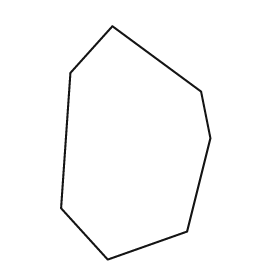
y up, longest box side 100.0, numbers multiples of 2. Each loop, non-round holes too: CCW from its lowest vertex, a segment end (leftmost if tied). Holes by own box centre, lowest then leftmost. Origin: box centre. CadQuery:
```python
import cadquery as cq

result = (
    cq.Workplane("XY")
    .moveTo(-12.0, -50.0)
    .lineTo(22.0, -38.0)
    .lineTo(32.0, 2.0)
    .lineTo(28.0, 22.0)
    .lineTo(-10.0, 50.0)
    .lineTo(-28.0, 30.0)
    .lineTo(-32.0, -28.0)
    .close()
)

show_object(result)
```